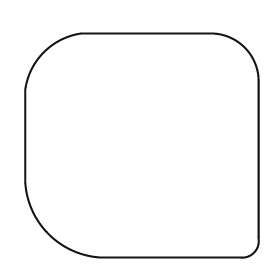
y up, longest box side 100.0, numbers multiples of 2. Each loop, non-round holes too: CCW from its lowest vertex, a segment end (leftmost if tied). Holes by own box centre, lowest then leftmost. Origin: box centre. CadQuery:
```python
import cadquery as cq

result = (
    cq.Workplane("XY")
    .moveTo(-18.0, -48.0)
    .lineTo(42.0, -48.0)
    .threePointArc((48.0, -46.0), (50.0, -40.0))
    .lineTo(50.0, 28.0)
    .threePointArc((44.0, 42.0), (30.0, 48.0))
    .lineTo(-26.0, 48.0)
    .threePointArc((-42.0, 40.0), (-50.0, 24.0))
    .lineTo(-50.0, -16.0)
    .threePointArc((-40.0, -38.0), (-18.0, -48.0))
    .close()
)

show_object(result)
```